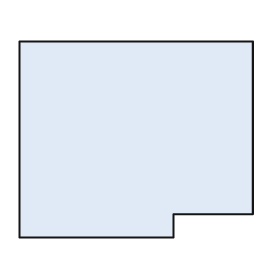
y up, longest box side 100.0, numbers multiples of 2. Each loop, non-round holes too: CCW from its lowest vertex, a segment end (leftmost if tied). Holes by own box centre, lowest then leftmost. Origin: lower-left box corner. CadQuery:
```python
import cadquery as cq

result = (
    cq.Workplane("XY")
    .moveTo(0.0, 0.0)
    .lineTo(66.0, 0.0)
    .lineTo(66.0, 10.0)
    .lineTo(100.0, 10.0)
    .lineTo(100.0, 84.0)
    .lineTo(0.0, 84.0)
    .close()
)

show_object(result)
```